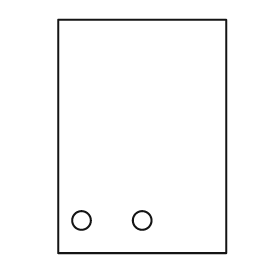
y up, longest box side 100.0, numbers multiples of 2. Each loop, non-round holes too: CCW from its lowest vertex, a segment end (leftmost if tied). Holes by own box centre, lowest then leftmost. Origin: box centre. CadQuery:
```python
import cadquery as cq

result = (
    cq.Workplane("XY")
    .moveTo(-36.0, -50.0)
    .lineTo(36.0, -50.0)
    .lineTo(36.0, 50.0)
    .lineTo(-36.0, 50.0)
    .close()
    .moveTo(-26.0, -36.0)
    .circle(4.0)
    .moveTo(0.0, -36.0)
    .circle(4.0)
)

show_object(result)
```